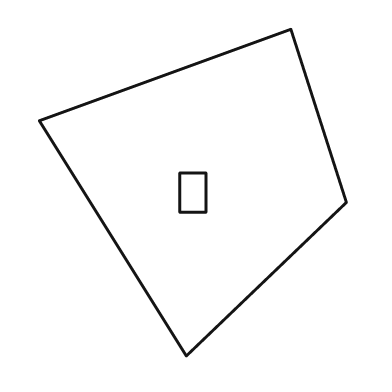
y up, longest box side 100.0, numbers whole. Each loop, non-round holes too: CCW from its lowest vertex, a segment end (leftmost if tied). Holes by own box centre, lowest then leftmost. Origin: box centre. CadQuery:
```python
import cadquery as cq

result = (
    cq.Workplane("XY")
    .moveTo(-2.0, -50.0)
    .lineTo(47.0, -3.0)
    .lineTo(30.0, 50.0)
    .lineTo(-47.0, 22.0)
    .close()
    .moveTo(-4.0, -6.0)
    .lineTo(4.0, -6.0)
    .lineTo(4.0, 6.0)
    .lineTo(-4.0, 6.0)
    .close()
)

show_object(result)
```